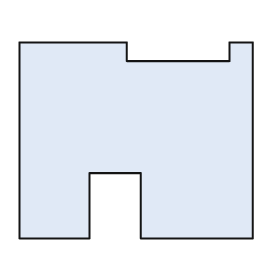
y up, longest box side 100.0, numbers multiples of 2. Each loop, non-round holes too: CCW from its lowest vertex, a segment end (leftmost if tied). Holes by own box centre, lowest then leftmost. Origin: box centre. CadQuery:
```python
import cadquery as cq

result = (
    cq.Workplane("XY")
    .moveTo(-50.0, -42.0)
    .lineTo(-20.0, -42.0)
    .lineTo(-20.0, -14.0)
    .lineTo(2.0, -14.0)
    .lineTo(2.0, -42.0)
    .lineTo(50.0, -42.0)
    .lineTo(50.0, 42.0)
    .lineTo(40.0, 42.0)
    .lineTo(40.0, 34.0)
    .lineTo(-4.0, 34.0)
    .lineTo(-4.0, 42.0)
    .lineTo(-50.0, 42.0)
    .close()
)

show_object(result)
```